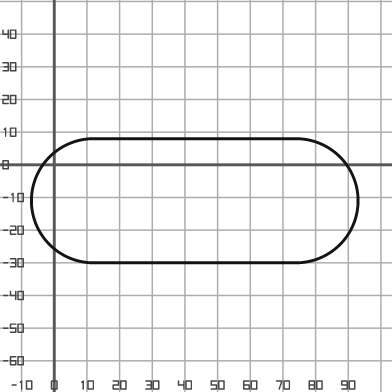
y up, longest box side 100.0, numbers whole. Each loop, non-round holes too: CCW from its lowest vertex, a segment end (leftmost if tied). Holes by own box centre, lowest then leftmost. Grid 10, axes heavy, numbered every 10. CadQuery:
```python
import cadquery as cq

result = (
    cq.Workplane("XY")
    .moveTo(12.0, -30.0)
    .lineTo(74.0, -30.0)
    .threePointArc((93.0, -11.0), (74.0, 8.0))
    .lineTo(12.0, 8.0)
    .threePointArc((-7.0, -11.0), (12.0, -30.0))
    .close()
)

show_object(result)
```